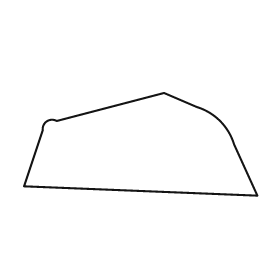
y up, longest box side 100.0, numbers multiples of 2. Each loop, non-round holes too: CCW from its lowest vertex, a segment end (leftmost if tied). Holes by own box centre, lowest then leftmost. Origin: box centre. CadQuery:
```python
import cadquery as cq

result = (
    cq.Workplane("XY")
    .moveTo(50.0, -22.0)
    .lineTo(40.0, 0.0)
    .threePointArc((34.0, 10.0), (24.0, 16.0))
    .lineTo(10.0, 22.0)
    .lineTo(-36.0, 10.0)
    .threePointArc((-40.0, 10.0), (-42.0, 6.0))
    .lineTo(-50.0, -18.0)
    .close()
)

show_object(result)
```